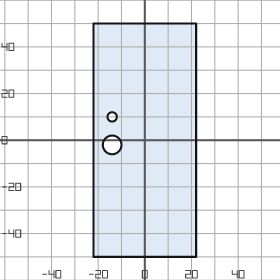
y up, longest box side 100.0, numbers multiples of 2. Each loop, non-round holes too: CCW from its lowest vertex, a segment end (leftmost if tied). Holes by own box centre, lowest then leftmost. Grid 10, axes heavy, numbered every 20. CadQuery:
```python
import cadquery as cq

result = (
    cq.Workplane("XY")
    .moveTo(-22.0, -50.0)
    .lineTo(22.0, -50.0)
    .lineTo(22.0, 50.0)
    .lineTo(-22.0, 50.0)
    .close()
    .moveTo(-14.0, -2.0)
    .circle(4.0)
    .moveTo(-14.0, 10.0)
    .circle(2.0)
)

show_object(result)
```